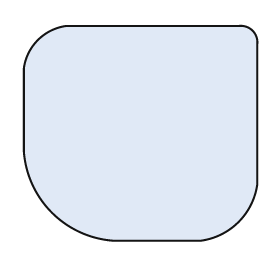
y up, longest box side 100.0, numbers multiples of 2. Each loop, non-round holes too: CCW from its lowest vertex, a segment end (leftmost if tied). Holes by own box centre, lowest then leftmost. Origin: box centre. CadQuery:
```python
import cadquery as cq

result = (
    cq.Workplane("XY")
    .moveTo(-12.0, -46.0)
    .lineTo(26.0, -46.0)
    .threePointArc((42.0, -38.0), (50.0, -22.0))
    .lineTo(50.0, 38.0)
    .threePointArc((48.0, 44.0), (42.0, 46.0))
    .lineTo(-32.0, 46.0)
    .threePointArc((-44.0, 40.0), (-50.0, 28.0))
    .lineTo(-50.0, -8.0)
    .threePointArc((-38.0, -34.0), (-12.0, -46.0))
    .close()
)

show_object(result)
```